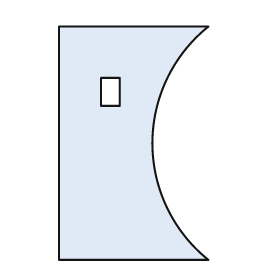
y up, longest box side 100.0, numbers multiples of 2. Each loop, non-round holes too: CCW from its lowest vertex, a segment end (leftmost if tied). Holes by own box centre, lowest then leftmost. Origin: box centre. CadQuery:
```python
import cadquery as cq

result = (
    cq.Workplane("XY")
    .moveTo(-32.0, -50.0)
    .lineTo(32.0, -50.0)
    .threePointArc((8.0, 0.0), (32.0, 50.0))
    .lineTo(-32.0, 50.0)
    .close()
    .moveTo(-14.0, 16.0)
    .lineTo(-6.0, 16.0)
    .lineTo(-6.0, 28.0)
    .lineTo(-14.0, 28.0)
    .close()
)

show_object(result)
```